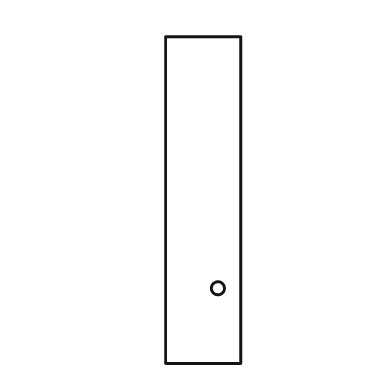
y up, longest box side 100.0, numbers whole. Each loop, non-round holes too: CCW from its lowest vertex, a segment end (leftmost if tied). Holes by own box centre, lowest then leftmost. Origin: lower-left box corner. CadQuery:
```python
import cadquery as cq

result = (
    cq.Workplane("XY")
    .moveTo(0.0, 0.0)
    .lineTo(23.0, 0.0)
    .lineTo(23.0, 100.0)
    .lineTo(0.0, 100.0)
    .close()
    .moveTo(16.0, 23.0)
    .circle(2.0)
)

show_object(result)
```